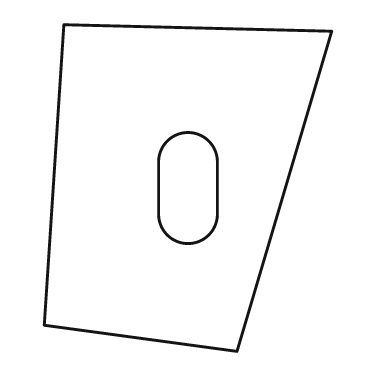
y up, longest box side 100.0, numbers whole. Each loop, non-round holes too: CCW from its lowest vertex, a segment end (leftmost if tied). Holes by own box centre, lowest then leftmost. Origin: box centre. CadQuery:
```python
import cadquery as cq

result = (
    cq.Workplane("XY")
    .moveTo(15.0, -50.0)
    .lineTo(44.0, 48.0)
    .lineTo(-38.0, 50.0)
    .lineTo(-44.0, -42.0)
    .close()
    .moveTo(-9.0, -8.0)
    .threePointArc((0.0, -17.0), (9.0, -8.0))
    .lineTo(9.0, 8.0)
    .threePointArc((0.0, 17.0), (-9.0, 8.0))
    .close()
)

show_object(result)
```